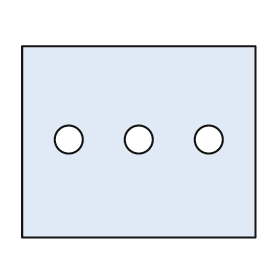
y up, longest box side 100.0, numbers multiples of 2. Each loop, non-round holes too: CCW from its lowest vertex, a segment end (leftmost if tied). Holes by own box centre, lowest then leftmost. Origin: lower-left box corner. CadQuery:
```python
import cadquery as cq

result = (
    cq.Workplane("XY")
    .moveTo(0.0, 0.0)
    .lineTo(100.0, 0.0)
    .lineTo(100.0, 82.0)
    .lineTo(0.0, 82.0)
    .close()
    .moveTo(20.0, 42.0)
    .circle(6.0)
    .moveTo(50.0, 42.0)
    .circle(6.0)
    .moveTo(80.0, 42.0)
    .circle(6.0)
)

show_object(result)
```